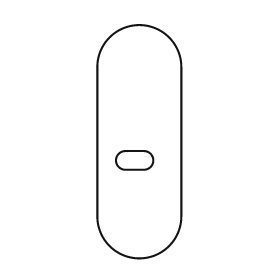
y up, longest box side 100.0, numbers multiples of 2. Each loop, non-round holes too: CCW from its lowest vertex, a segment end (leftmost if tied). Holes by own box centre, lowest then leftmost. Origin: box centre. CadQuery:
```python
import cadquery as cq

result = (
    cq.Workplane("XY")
    .moveTo(-18.0, -32.0)
    .threePointArc((0.0, -50.0), (18.0, -32.0))
    .lineTo(18.0, 32.0)
    .threePointArc((0.0, 50.0), (-18.0, 32.0))
    .close()
    .moveTo(-6.0, -12.0)
    .lineTo(2.0, -12.0)
    .threePointArc((6.0, -8.0), (2.0, -4.0))
    .lineTo(-6.0, -4.0)
    .threePointArc((-10.0, -8.0), (-6.0, -12.0))
    .close()
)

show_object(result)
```